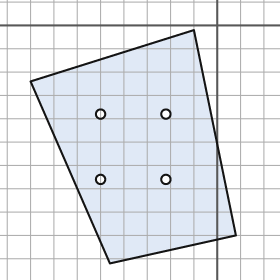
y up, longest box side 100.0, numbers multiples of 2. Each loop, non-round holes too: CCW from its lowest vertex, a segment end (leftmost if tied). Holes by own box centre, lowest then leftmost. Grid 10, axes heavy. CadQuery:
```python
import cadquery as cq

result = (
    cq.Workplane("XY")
    .moveTo(-46.0, -102.0)
    .lineTo(8.0, -90.0)
    .lineTo(-10.0, -2.0)
    .lineTo(-80.0, -24.0)
    .close()
    .moveTo(-50.0, -66.0)
    .circle(2.0)
    .moveTo(-22.0, -66.0)
    .circle(2.0)
    .moveTo(-50.0, -38.0)
    .circle(2.0)
    .moveTo(-22.0, -38.0)
    .circle(2.0)
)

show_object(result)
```